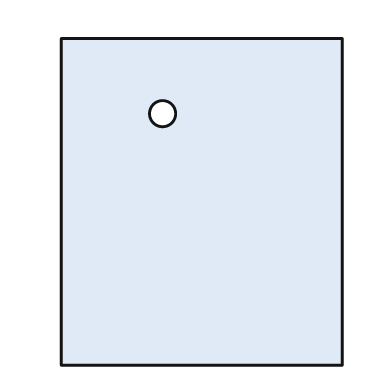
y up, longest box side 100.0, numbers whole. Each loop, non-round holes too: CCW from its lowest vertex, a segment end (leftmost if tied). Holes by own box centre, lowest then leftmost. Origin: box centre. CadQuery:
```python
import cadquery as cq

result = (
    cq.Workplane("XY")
    .moveTo(-43.0, -50.0)
    .lineTo(43.0, -50.0)
    .lineTo(43.0, 50.0)
    .lineTo(-43.0, 50.0)
    .close()
    .moveTo(-12.0, 27.0)
    .circle(4.0)
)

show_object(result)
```